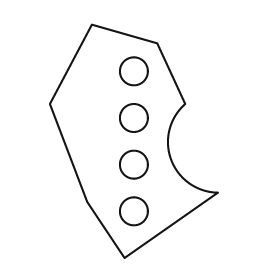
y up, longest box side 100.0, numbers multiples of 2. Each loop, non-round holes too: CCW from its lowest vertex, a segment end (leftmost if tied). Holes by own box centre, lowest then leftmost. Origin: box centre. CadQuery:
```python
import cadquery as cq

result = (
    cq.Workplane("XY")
    .moveTo(-4.0, -50.0)
    .lineTo(36.0, -22.0)
    .threePointArc((16.0, -8.0), (22.0, 16.0))
    .lineTo(10.0, 42.0)
    .lineTo(-18.0, 50.0)
    .lineTo(-36.0, 16.0)
    .lineTo(-20.0, -26.0)
    .close()
    .moveTo(0.0, -30.0)
    .circle(6.0)
    .moveTo(0.0, -10.0)
    .circle(6.0)
    .moveTo(0.0, 10.0)
    .circle(6.0)
    .moveTo(0.0, 30.0)
    .circle(6.0)
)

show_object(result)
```